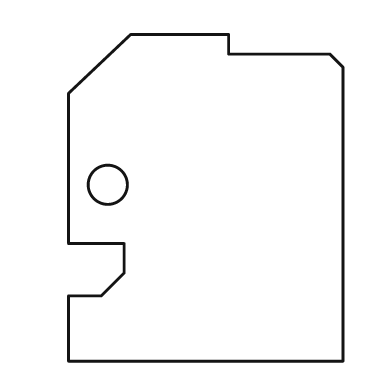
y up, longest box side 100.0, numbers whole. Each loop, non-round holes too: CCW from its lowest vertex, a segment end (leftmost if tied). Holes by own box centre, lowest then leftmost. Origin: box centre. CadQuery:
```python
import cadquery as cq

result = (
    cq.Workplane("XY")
    .moveTo(-42.0, -50.0)
    .lineTo(42.0, -50.0)
    .lineTo(42.0, 40.0)
    .lineTo(38.0, 44.0)
    .lineTo(7.0, 44.0)
    .lineTo(7.0, 50.0)
    .lineTo(-23.0, 50.0)
    .lineTo(-42.0, 32.0)
    .lineTo(-42.0, -14.0)
    .lineTo(-25.0, -14.0)
    .lineTo(-25.0, -23.0)
    .lineTo(-32.0, -30.0)
    .lineTo(-42.0, -30.0)
    .close()
    .moveTo(-30.0, 4.0)
    .circle(6.0)
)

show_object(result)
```